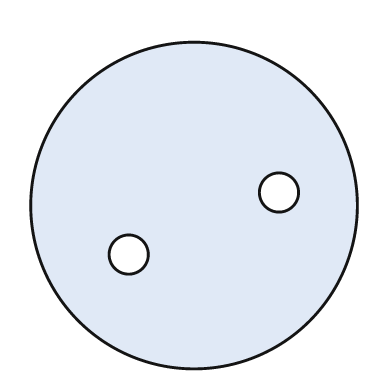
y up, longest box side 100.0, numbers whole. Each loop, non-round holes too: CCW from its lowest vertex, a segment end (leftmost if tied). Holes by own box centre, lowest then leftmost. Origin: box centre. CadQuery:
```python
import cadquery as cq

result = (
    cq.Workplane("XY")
    .moveTo(0.0, 0.0)
    .circle(50.0)
    .moveTo(-20.0, -15.0)
    .circle(6.0)
    .moveTo(26.0, 4.0)
    .circle(6.0)
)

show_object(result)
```